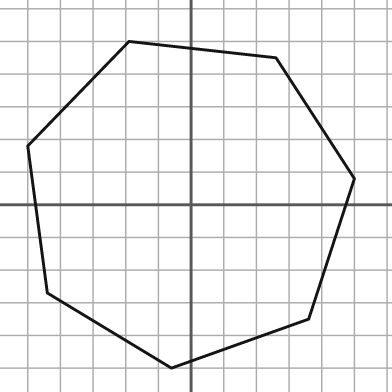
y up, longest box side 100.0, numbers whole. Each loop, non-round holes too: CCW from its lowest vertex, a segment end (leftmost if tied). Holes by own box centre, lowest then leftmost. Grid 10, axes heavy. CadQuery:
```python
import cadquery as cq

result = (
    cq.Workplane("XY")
    .moveTo(-6.0, -50.0)
    .lineTo(36.0, -35.0)
    .lineTo(50.0, 8.0)
    .lineTo(26.0, 45.0)
    .lineTo(-19.0, 50.0)
    .lineTo(-50.0, 18.0)
    .lineTo(-44.0, -27.0)
    .close()
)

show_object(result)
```